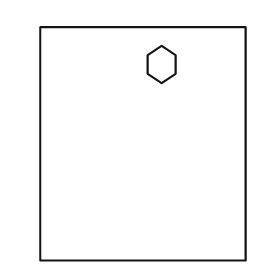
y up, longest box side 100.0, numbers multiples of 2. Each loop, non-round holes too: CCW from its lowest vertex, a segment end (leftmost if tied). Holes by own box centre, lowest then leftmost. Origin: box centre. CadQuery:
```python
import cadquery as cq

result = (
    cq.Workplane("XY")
    .moveTo(-44.0, -50.0)
    .lineTo(44.0, -50.0)
    .lineTo(44.0, 50.0)
    .lineTo(-44.0, 50.0)
    .close()
    .moveTo(8.0, 26.0)
    .lineTo(14.0, 30.0)
    .lineTo(14.0, 38.0)
    .lineTo(8.0, 42.0)
    .lineTo(2.0, 38.0)
    .lineTo(2.0, 30.0)
    .close()
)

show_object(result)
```